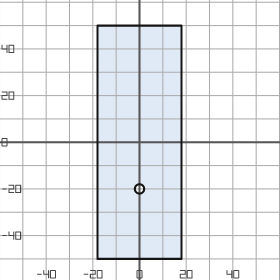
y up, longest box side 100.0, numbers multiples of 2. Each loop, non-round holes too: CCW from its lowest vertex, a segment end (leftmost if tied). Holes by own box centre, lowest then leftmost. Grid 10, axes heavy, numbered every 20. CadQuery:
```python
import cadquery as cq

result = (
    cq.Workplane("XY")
    .moveTo(-18.0, -50.0)
    .lineTo(18.0, -50.0)
    .lineTo(18.0, 50.0)
    .lineTo(-18.0, 50.0)
    .close()
    .moveTo(0.0, -20.0)
    .circle(2.0)
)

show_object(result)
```